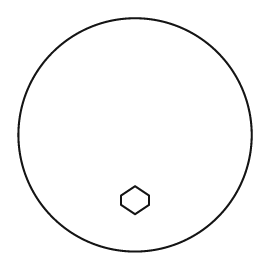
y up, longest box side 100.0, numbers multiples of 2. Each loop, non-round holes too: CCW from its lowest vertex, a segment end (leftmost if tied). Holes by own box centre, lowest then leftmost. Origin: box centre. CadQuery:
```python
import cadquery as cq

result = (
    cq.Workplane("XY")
    .moveTo(0.0, 0.0)
    .circle(50.0)
    .moveTo(0.0, -34.0)
    .lineTo(6.0, -30.0)
    .lineTo(6.0, -26.0)
    .lineTo(0.0, -22.0)
    .lineTo(-6.0, -26.0)
    .lineTo(-6.0, -30.0)
    .close()
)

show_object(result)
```